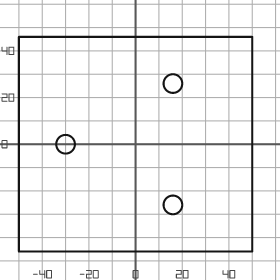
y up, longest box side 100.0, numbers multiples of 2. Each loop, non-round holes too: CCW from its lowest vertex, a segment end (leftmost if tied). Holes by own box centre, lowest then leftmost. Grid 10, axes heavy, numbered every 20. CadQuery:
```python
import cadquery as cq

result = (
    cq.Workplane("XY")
    .moveTo(-50.0, -46.0)
    .lineTo(50.0, -46.0)
    .lineTo(50.0, 46.0)
    .lineTo(-50.0, 46.0)
    .close()
    .moveTo(16.0, -26.0)
    .circle(4.0)
    .moveTo(-30.0, 0.0)
    .circle(4.0)
    .moveTo(16.0, 26.0)
    .circle(4.0)
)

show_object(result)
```